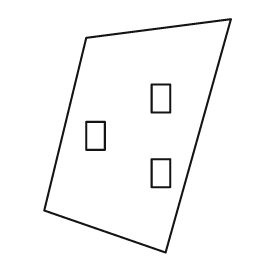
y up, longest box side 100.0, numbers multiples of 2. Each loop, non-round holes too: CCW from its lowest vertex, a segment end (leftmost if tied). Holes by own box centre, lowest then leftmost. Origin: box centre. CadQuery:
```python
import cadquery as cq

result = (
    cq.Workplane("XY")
    .moveTo(12.0, -50.0)
    .lineTo(40.0, 50.0)
    .lineTo(-22.0, 42.0)
    .lineTo(-40.0, -32.0)
    .close()
    .moveTo(6.0, -22.0)
    .lineTo(14.0, -22.0)
    .lineTo(14.0, -10.0)
    .lineTo(6.0, -10.0)
    .close()
    .moveTo(-22.0, -6.0)
    .lineTo(-14.0, -6.0)
    .lineTo(-14.0, 6.0)
    .lineTo(-22.0, 6.0)
    .close()
    .moveTo(6.0, 10.0)
    .lineTo(14.0, 10.0)
    .lineTo(14.0, 22.0)
    .lineTo(6.0, 22.0)
    .close()
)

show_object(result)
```